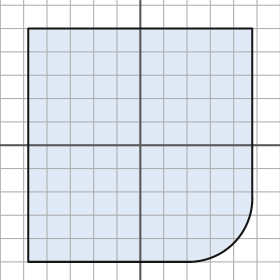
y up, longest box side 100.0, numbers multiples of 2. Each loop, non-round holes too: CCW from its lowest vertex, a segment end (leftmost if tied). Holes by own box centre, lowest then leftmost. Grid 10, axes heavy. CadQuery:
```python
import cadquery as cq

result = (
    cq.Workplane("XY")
    .moveTo(-48.0, -50.0)
    .lineTo(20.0, -50.0)
    .threePointArc((40.0, -42.0), (48.0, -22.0))
    .lineTo(48.0, 50.0)
    .lineTo(-48.0, 50.0)
    .close()
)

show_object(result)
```